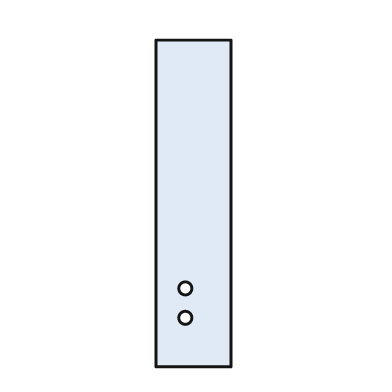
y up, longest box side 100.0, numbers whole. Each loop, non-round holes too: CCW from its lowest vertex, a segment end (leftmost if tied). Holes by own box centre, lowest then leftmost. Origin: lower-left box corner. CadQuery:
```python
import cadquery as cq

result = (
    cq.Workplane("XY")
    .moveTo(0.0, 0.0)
    .lineTo(23.0, 0.0)
    .lineTo(23.0, 100.0)
    .lineTo(0.0, 100.0)
    .close()
    .moveTo(9.0, 15.0)
    .circle(2.0)
    .moveTo(9.0, 24.0)
    .circle(2.0)
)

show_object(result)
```